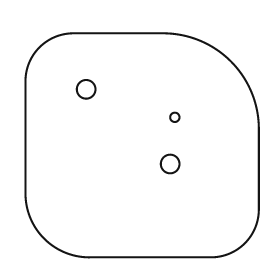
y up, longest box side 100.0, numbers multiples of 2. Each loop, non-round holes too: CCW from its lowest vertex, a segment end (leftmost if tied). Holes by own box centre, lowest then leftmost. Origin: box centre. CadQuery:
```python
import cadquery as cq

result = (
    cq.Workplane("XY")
    .moveTo(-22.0, -48.0)
    .lineTo(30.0, -48.0)
    .threePointArc((44.0, -42.0), (50.0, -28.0))
    .lineTo(50.0, 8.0)
    .threePointArc((38.0, 36.0), (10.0, 48.0))
    .lineTo(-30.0, 48.0)
    .threePointArc((-44.0, 42.0), (-50.0, 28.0))
    .lineTo(-50.0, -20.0)
    .threePointArc((-42.0, -40.0), (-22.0, -48.0))
    .close()
    .moveTo(12.0, -8.0)
    .circle(4.0)
    .moveTo(14.0, 12.0)
    .circle(2.0)
    .moveTo(-24.0, 24.0)
    .circle(4.0)
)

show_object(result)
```